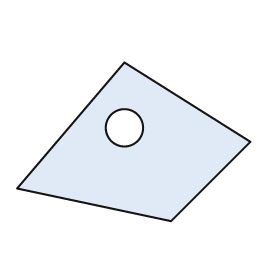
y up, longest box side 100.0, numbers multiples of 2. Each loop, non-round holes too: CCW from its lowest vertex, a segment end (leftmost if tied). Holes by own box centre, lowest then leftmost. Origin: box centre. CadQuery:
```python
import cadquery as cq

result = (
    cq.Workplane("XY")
    .moveTo(16.0, -34.0)
    .lineTo(50.0, 0.0)
    .lineTo(-4.0, 34.0)
    .lineTo(-50.0, -20.0)
    .close()
    .moveTo(-4.0, 6.0)
    .circle(8.0)
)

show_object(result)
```